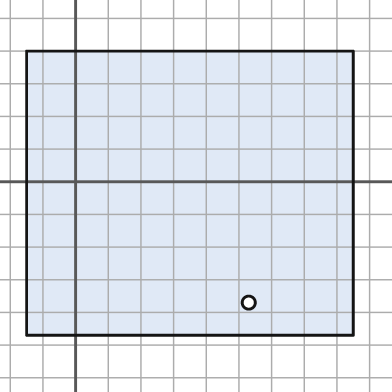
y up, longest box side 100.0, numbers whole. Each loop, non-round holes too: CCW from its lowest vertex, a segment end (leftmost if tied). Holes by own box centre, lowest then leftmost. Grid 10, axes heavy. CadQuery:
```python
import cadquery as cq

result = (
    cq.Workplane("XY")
    .moveTo(-15.0, -47.0)
    .lineTo(85.0, -47.0)
    .lineTo(85.0, 40.0)
    .lineTo(-15.0, 40.0)
    .close()
    .moveTo(53.0, -37.0)
    .circle(2.0)
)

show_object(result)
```